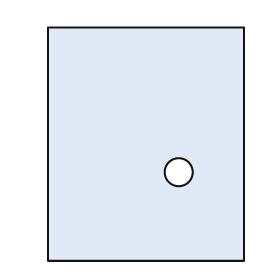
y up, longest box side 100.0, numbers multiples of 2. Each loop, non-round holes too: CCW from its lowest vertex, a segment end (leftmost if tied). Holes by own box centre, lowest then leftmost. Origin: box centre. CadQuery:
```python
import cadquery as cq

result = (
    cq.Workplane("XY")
    .moveTo(-42.0, -50.0)
    .lineTo(42.0, -50.0)
    .lineTo(42.0, 50.0)
    .lineTo(-42.0, 50.0)
    .close()
    .moveTo(14.0, -12.0)
    .circle(6.0)
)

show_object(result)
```